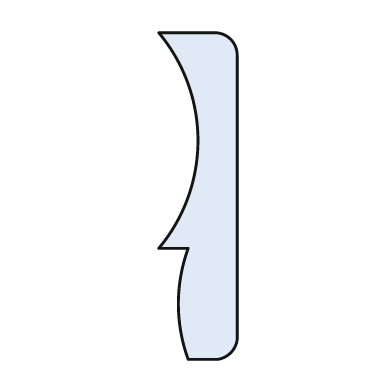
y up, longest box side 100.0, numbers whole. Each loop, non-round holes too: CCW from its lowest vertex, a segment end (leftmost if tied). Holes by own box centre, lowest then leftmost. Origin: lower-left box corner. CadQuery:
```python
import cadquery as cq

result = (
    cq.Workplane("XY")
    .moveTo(9.0, 0.0)
    .lineTo(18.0, 0.0)
    .threePointArc((22.0, 2.0), (24.0, 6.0))
    .lineTo(24.0, 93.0)
    .threePointArc((22.0, 98.0), (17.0, 100.0))
    .lineTo(0.0, 100.0)
    .threePointArc((12.0, 67.0), (0.0, 34.0))
    .lineTo(9.0, 34.0)
    .threePointArc((6.0, 17.0), (9.0, 0.0))
    .close()
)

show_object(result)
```